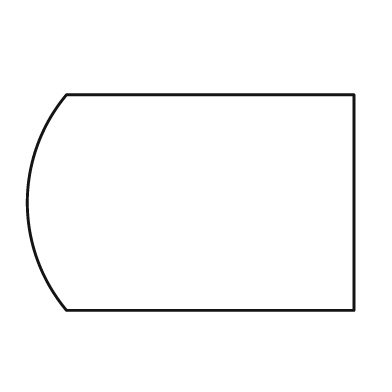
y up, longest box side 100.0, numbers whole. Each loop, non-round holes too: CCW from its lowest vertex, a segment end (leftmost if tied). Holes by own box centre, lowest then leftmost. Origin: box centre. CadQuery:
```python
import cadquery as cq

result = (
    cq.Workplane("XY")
    .moveTo(-38.0, -33.0)
    .lineTo(50.0, -33.0)
    .lineTo(50.0, 33.0)
    .lineTo(-38.0, 33.0)
    .threePointArc((-50.0, 0.0), (-38.0, -33.0))
    .close()
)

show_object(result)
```